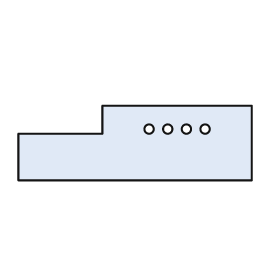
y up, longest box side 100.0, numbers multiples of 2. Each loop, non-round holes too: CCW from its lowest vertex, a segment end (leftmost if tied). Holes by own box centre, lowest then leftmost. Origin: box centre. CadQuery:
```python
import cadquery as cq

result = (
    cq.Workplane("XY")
    .moveTo(-50.0, -16.0)
    .lineTo(50.0, -16.0)
    .lineTo(50.0, 16.0)
    .lineTo(-14.0, 16.0)
    .lineTo(-14.0, 4.0)
    .lineTo(-50.0, 4.0)
    .close()
    .moveTo(6.0, 6.0)
    .circle(2.0)
    .moveTo(14.0, 6.0)
    .circle(2.0)
    .moveTo(22.0, 6.0)
    .circle(2.0)
    .moveTo(30.0, 6.0)
    .circle(2.0)
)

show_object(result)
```